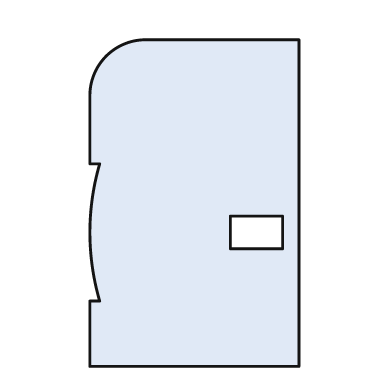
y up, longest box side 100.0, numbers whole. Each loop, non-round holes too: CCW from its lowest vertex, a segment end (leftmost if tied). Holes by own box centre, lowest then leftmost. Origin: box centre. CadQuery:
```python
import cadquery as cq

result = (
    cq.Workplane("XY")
    .moveTo(-32.0, -50.0)
    .lineTo(32.0, -50.0)
    .lineTo(32.0, 50.0)
    .lineTo(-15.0, 50.0)
    .threePointArc((-27.0, 45.0), (-32.0, 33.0))
    .lineTo(-32.0, 12.0)
    .lineTo(-29.0, 12.0)
    .threePointArc((-32.0, -9.0), (-29.0, -30.0))
    .lineTo(-32.0, -30.0)
    .close()
    .moveTo(11.0, -14.0)
    .lineTo(27.0, -14.0)
    .lineTo(27.0, -4.0)
    .lineTo(11.0, -4.0)
    .close()
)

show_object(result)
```